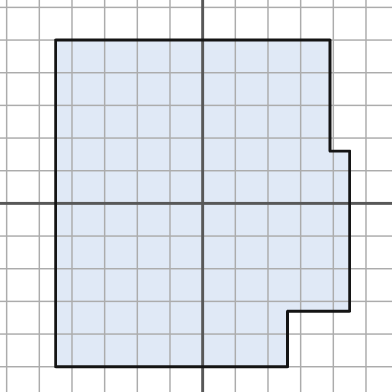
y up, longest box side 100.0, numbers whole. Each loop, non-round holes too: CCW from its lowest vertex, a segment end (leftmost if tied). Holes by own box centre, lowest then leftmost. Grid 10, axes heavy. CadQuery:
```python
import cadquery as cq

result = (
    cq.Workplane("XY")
    .moveTo(-45.0, -50.0)
    .lineTo(26.0, -50.0)
    .lineTo(26.0, -33.0)
    .lineTo(45.0, -33.0)
    .lineTo(45.0, 16.0)
    .lineTo(39.0, 16.0)
    .lineTo(39.0, 50.0)
    .lineTo(-45.0, 50.0)
    .close()
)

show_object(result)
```